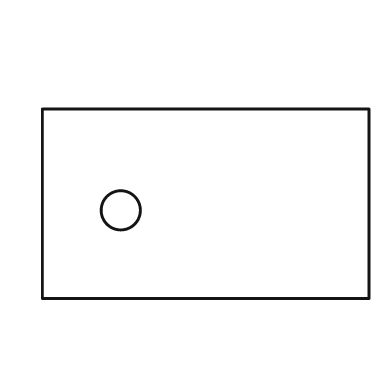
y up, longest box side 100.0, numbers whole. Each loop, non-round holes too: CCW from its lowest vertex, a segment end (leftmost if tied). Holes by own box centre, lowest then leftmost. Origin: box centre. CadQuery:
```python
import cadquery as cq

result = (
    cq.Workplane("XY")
    .moveTo(-50.0, -29.0)
    .lineTo(50.0, -29.0)
    .lineTo(50.0, 29.0)
    .lineTo(-50.0, 29.0)
    .close()
    .moveTo(-26.0, -2.0)
    .circle(6.0)
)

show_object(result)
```